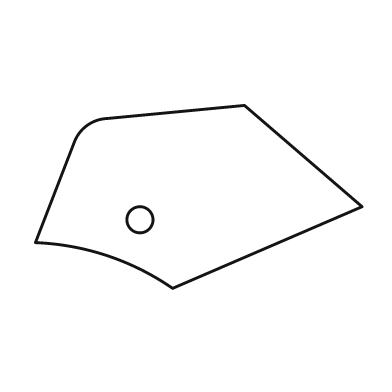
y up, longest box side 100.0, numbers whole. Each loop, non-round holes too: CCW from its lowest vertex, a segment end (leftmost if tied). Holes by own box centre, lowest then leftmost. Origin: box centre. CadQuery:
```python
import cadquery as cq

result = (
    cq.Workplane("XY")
    .moveTo(-8.0, -28.0)
    .lineTo(50.0, -3.0)
    .lineTo(14.0, 28.0)
    .lineTo(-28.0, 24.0)
    .threePointArc((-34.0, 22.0), (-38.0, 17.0))
    .lineTo(-50.0, -14.0)
    .threePointArc((-28.0, -18.0), (-8.0, -28.0))
    .close()
    .moveTo(-18.0, -7.0)
    .circle(4.0)
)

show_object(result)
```